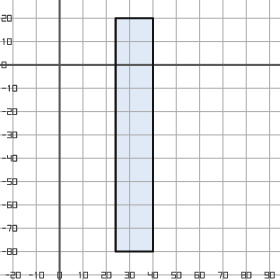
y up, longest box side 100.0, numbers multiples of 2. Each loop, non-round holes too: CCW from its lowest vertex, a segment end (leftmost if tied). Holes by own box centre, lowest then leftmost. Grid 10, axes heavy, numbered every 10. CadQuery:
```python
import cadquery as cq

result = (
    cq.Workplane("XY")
    .moveTo(24.0, -80.0)
    .lineTo(40.0, -80.0)
    .lineTo(40.0, 20.0)
    .lineTo(24.0, 20.0)
    .close()
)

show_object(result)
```